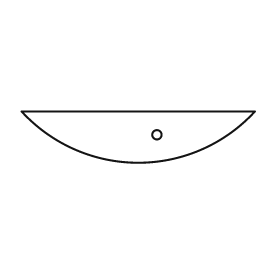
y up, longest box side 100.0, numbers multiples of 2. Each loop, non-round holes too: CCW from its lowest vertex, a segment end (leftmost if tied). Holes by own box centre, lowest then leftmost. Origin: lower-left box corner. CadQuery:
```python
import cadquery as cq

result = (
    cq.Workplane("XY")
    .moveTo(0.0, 22.0)
    .threePointArc((50.0, 0.0), (100.0, 22.0))
    .close()
    .moveTo(58.0, 12.0)
    .circle(2.0)
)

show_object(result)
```